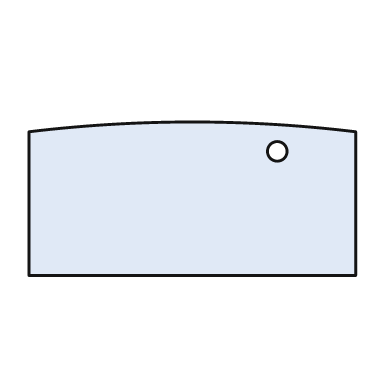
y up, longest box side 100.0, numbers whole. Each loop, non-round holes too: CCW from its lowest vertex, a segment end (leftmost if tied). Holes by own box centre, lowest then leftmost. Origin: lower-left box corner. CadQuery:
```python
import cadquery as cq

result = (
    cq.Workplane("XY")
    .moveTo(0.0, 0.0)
    .lineTo(100.0, 0.0)
    .lineTo(100.0, 44.0)
    .threePointArc((50.0, 47.0), (0.0, 44.0))
    .close()
    .moveTo(76.0, 38.0)
    .circle(3.0)
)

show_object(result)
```